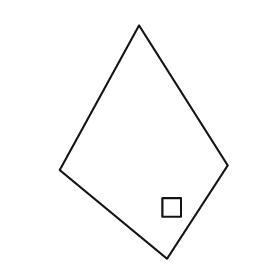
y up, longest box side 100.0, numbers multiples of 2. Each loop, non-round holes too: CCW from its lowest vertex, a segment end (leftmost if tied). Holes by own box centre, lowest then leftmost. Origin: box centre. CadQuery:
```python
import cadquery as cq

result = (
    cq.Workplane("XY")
    .moveTo(10.0, -50.0)
    .lineTo(36.0, -10.0)
    .lineTo(-2.0, 50.0)
    .lineTo(-36.0, -12.0)
    .close()
    .moveTo(8.0, -32.0)
    .lineTo(16.0, -32.0)
    .lineTo(16.0, -24.0)
    .lineTo(8.0, -24.0)
    .close()
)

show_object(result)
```